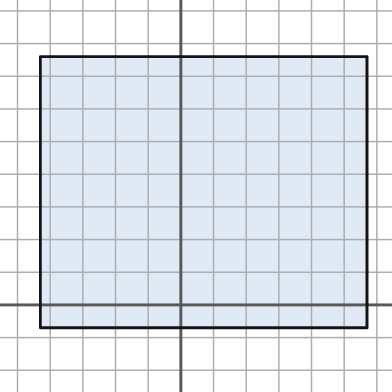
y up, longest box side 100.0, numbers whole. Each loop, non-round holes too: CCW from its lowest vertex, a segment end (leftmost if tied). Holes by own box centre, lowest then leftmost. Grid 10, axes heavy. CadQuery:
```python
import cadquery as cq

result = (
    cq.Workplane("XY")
    .moveTo(-43.0, -7.0)
    .lineTo(57.0, -7.0)
    .lineTo(57.0, 76.0)
    .lineTo(-43.0, 76.0)
    .close()
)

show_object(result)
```